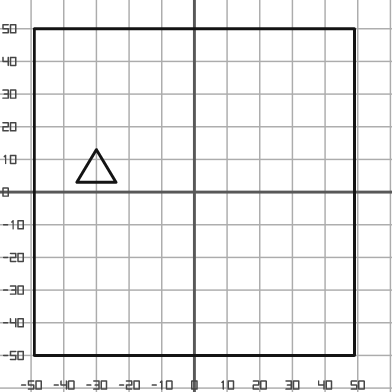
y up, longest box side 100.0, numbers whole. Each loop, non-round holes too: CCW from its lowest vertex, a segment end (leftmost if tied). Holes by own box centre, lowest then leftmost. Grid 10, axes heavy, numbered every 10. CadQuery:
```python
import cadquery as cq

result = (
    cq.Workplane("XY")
    .moveTo(-49.0, -50.0)
    .lineTo(49.0, -50.0)
    .lineTo(49.0, 50.0)
    .lineTo(-49.0, 50.0)
    .close()
    .moveTo(-36.0, 3.0)
    .lineTo(-24.0, 3.0)
    .lineTo(-30.0, 13.0)
    .close()
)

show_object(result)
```